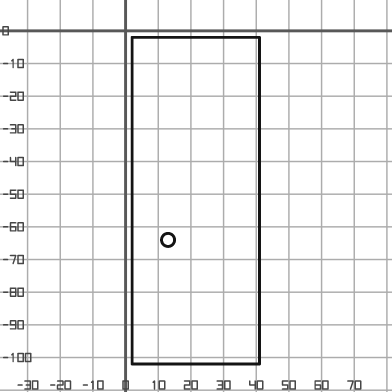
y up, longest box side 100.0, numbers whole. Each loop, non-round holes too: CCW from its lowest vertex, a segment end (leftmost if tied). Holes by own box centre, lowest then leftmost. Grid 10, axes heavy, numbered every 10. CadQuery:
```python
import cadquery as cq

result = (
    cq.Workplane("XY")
    .moveTo(2.0, -102.0)
    .lineTo(41.0, -102.0)
    .lineTo(41.0, -2.0)
    .lineTo(2.0, -2.0)
    .close()
    .moveTo(13.0, -64.0)
    .circle(2.0)
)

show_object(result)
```